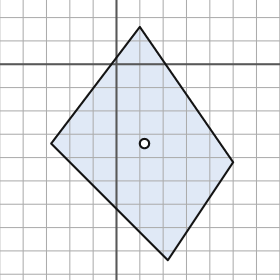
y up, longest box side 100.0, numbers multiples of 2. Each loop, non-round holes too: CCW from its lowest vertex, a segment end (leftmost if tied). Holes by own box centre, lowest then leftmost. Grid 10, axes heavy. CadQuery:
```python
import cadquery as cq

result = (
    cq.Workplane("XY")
    .moveTo(22.0, -84.0)
    .lineTo(50.0, -42.0)
    .lineTo(10.0, 16.0)
    .lineTo(-28.0, -34.0)
    .close()
    .moveTo(12.0, -34.0)
    .circle(2.0)
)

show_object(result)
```